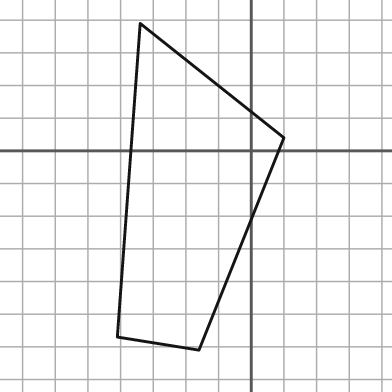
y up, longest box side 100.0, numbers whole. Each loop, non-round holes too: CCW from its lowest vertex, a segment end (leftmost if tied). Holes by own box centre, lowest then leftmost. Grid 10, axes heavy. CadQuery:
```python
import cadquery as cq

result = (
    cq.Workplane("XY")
    .moveTo(-16.0, -61.0)
    .lineTo(10.0, 4.0)
    .lineTo(-34.0, 39.0)
    .lineTo(-41.0, -57.0)
    .close()
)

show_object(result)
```